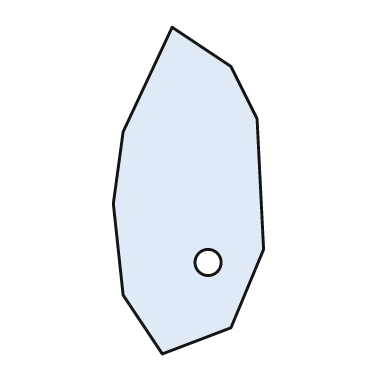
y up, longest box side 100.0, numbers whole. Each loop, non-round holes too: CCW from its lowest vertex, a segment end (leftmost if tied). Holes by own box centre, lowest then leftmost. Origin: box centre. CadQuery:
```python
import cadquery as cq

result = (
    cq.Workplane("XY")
    .moveTo(-8.0, -50.0)
    .lineTo(13.0, -42.0)
    .lineTo(23.0, -18.0)
    .lineTo(21.0, 22.0)
    .lineTo(13.0, 38.0)
    .lineTo(-5.0, 50.0)
    .lineTo(-20.0, 18.0)
    .lineTo(-23.0, -4.0)
    .lineTo(-20.0, -32.0)
    .close()
    .moveTo(6.0, -22.0)
    .circle(4.0)
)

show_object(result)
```